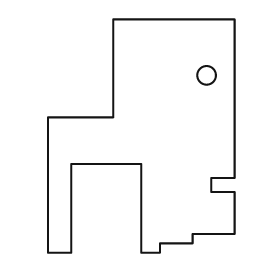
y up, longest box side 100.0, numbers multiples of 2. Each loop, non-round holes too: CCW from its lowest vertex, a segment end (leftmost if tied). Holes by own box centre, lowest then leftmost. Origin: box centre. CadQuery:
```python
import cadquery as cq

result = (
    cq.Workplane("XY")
    .moveTo(-40.0, -50.0)
    .lineTo(-30.0, -50.0)
    .lineTo(-30.0, -12.0)
    .lineTo(0.0, -12.0)
    .lineTo(0.0, -50.0)
    .lineTo(8.0, -50.0)
    .lineTo(8.0, -46.0)
    .lineTo(22.0, -46.0)
    .lineTo(22.0, -42.0)
    .lineTo(40.0, -42.0)
    .lineTo(40.0, -24.0)
    .lineTo(30.0, -24.0)
    .lineTo(30.0, -18.0)
    .lineTo(40.0, -18.0)
    .lineTo(40.0, 50.0)
    .lineTo(-12.0, 50.0)
    .lineTo(-12.0, 8.0)
    .lineTo(-40.0, 8.0)
    .close()
    .moveTo(28.0, 26.0)
    .circle(4.0)
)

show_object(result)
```